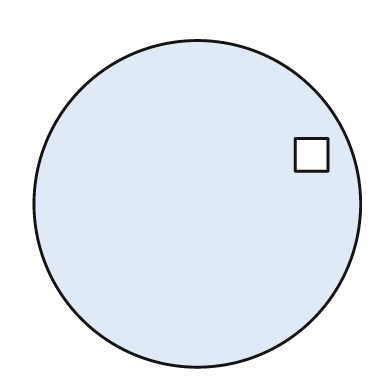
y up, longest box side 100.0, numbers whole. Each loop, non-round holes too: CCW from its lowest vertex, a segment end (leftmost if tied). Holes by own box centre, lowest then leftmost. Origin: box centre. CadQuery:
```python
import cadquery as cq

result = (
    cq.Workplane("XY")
    .moveTo(0.0, 0.0)
    .circle(50.0)
    .moveTo(30.0, 10.0)
    .lineTo(40.0, 10.0)
    .lineTo(40.0, 20.0)
    .lineTo(30.0, 20.0)
    .close()
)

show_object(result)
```